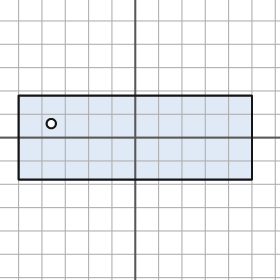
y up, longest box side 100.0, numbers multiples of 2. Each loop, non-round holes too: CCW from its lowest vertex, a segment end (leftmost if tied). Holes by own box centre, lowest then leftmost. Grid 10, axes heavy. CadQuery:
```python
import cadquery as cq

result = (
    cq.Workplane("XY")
    .moveTo(-50.0, -18.0)
    .lineTo(50.0, -18.0)
    .lineTo(50.0, 18.0)
    .lineTo(-50.0, 18.0)
    .close()
    .moveTo(-36.0, 6.0)
    .circle(2.0)
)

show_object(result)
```